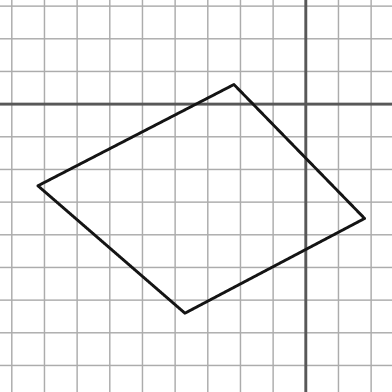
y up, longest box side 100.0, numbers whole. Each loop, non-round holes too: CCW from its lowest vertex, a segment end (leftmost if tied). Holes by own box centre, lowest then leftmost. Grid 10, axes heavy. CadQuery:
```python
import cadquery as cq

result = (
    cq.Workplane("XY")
    .moveTo(-37.0, -64.0)
    .lineTo(18.0, -35.0)
    .lineTo(-22.0, 6.0)
    .lineTo(-82.0, -25.0)
    .close()
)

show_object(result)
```